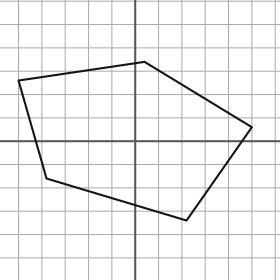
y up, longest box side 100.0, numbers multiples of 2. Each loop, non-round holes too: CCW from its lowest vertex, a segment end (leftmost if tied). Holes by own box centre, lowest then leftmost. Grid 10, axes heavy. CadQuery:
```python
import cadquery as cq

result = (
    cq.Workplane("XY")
    .moveTo(22.0, -34.0)
    .lineTo(50.0, 6.0)
    .lineTo(4.0, 34.0)
    .lineTo(-50.0, 26.0)
    .lineTo(-38.0, -16.0)
    .close()
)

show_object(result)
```